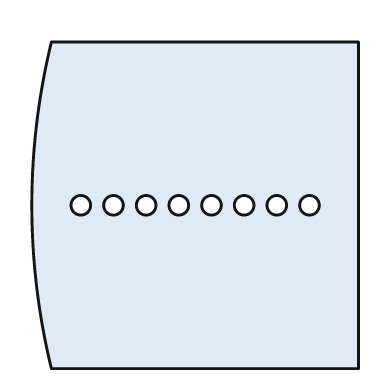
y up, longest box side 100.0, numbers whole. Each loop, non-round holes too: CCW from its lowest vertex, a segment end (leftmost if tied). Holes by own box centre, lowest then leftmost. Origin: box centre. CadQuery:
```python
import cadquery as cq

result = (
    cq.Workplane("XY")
    .moveTo(-44.0, -50.0)
    .lineTo(50.0, -50.0)
    .lineTo(50.0, 50.0)
    .lineTo(-44.0, 50.0)
    .threePointArc((-50.0, 0.0), (-44.0, -50.0))
    .close()
    .moveTo(-35.0, 0.0)
    .circle(3.0)
    .moveTo(-25.0, 0.0)
    .circle(3.0)
    .moveTo(-15.0, 0.0)
    .circle(3.0)
    .moveTo(-5.0, 0.0)
    .circle(3.0)
    .moveTo(5.0, 0.0)
    .circle(3.0)
    .moveTo(15.0, 0.0)
    .circle(3.0)
    .moveTo(25.0, 0.0)
    .circle(3.0)
    .moveTo(35.0, 0.0)
    .circle(3.0)
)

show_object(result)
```